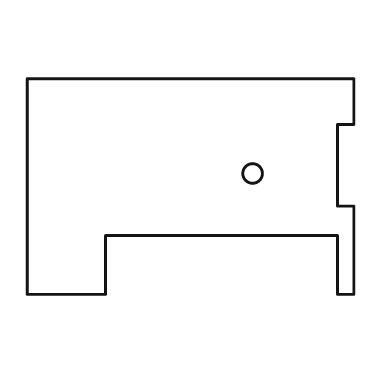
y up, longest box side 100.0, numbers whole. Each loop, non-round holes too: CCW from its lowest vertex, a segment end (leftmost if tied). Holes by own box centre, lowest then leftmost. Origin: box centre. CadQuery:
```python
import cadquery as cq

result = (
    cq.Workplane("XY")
    .moveTo(-50.0, -33.0)
    .lineTo(-26.0, -33.0)
    .lineTo(-26.0, -15.0)
    .lineTo(45.0, -15.0)
    .lineTo(45.0, -33.0)
    .lineTo(50.0, -33.0)
    .lineTo(50.0, -6.0)
    .lineTo(45.0, -6.0)
    .lineTo(45.0, 19.0)
    .lineTo(50.0, 19.0)
    .lineTo(50.0, 33.0)
    .lineTo(-50.0, 33.0)
    .close()
    .moveTo(19.0, 4.0)
    .circle(3.0)
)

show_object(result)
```